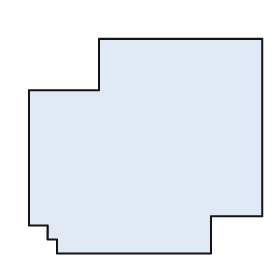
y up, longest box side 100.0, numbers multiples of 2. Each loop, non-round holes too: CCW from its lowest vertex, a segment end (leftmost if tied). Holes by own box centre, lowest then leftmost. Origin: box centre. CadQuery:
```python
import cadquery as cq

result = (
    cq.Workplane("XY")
    .moveTo(-38.0, -46.0)
    .lineTo(28.0, -46.0)
    .lineTo(28.0, -30.0)
    .lineTo(50.0, -30.0)
    .lineTo(50.0, 46.0)
    .lineTo(-20.0, 46.0)
    .lineTo(-20.0, 24.0)
    .lineTo(-50.0, 24.0)
    .lineTo(-50.0, -34.0)
    .lineTo(-42.0, -34.0)
    .lineTo(-42.0, -40.0)
    .lineTo(-38.0, -40.0)
    .close()
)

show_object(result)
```